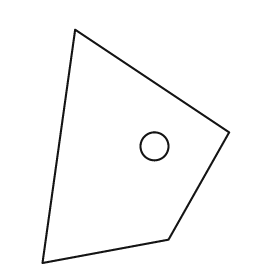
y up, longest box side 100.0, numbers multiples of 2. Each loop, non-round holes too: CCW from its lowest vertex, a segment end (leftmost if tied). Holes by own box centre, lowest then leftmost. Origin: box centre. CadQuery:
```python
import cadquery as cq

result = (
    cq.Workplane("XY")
    .moveTo(-40.0, -50.0)
    .lineTo(14.0, -40.0)
    .lineTo(40.0, 6.0)
    .lineTo(-26.0, 50.0)
    .close()
    .moveTo(8.0, 0.0)
    .circle(6.0)
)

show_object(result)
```